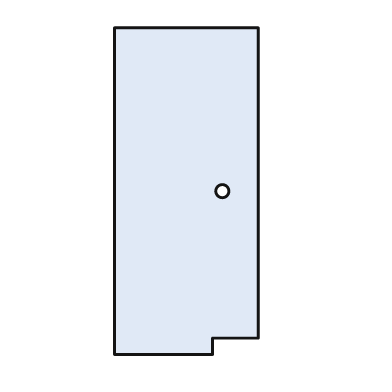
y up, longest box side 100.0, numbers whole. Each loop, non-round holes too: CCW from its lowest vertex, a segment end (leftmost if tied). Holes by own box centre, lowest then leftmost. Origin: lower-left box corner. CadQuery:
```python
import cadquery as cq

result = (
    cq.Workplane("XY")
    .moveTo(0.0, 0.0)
    .lineTo(30.0, 0.0)
    .lineTo(30.0, 5.0)
    .lineTo(44.0, 5.0)
    .lineTo(44.0, 100.0)
    .lineTo(0.0, 100.0)
    .close()
    .moveTo(33.0, 50.0)
    .circle(2.0)
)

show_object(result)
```